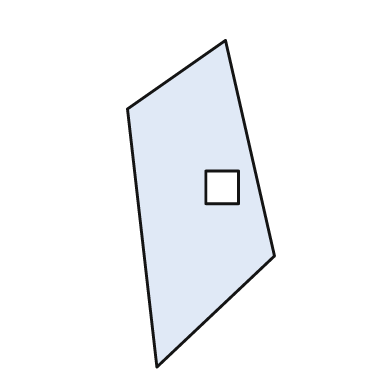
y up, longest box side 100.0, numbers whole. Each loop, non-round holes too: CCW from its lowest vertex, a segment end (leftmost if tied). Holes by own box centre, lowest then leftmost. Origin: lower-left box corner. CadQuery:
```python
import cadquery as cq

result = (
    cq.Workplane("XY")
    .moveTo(9.0, 0.0)
    .lineTo(45.0, 34.0)
    .lineTo(30.0, 100.0)
    .lineTo(0.0, 79.0)
    .close()
    .moveTo(24.0, 50.0)
    .lineTo(34.0, 50.0)
    .lineTo(34.0, 60.0)
    .lineTo(24.0, 60.0)
    .close()
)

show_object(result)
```